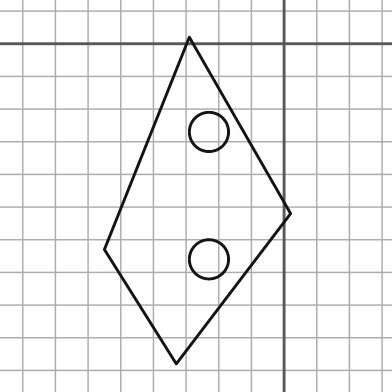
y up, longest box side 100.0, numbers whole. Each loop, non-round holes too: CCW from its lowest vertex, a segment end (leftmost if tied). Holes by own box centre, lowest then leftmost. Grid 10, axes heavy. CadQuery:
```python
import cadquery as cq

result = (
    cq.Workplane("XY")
    .moveTo(-33.0, -98.0)
    .lineTo(2.0, -52.0)
    .lineTo(-29.0, 2.0)
    .lineTo(-55.0, -63.0)
    .close()
    .moveTo(-23.0, -66.0)
    .circle(6.0)
    .moveTo(-23.0, -27.0)
    .circle(6.0)
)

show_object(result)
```